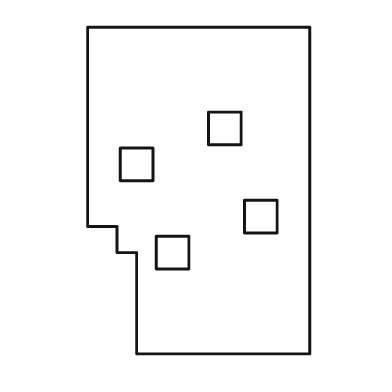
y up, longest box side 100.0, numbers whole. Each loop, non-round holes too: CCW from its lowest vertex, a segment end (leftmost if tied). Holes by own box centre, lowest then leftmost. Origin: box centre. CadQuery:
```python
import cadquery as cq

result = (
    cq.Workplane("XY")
    .moveTo(-19.0, -50.0)
    .lineTo(34.0, -50.0)
    .lineTo(34.0, 50.0)
    .lineTo(-34.0, 50.0)
    .lineTo(-34.0, -11.0)
    .lineTo(-25.0, -11.0)
    .lineTo(-25.0, -19.0)
    .lineTo(-19.0, -19.0)
    .close()
    .moveTo(-13.0, -24.0)
    .lineTo(-3.0, -24.0)
    .lineTo(-3.0, -14.0)
    .lineTo(-13.0, -14.0)
    .close()
    .moveTo(14.0, -13.0)
    .lineTo(24.0, -13.0)
    .lineTo(24.0, -3.0)
    .lineTo(14.0, -3.0)
    .close()
    .moveTo(-24.0, 3.0)
    .lineTo(-14.0, 3.0)
    .lineTo(-14.0, 13.0)
    .lineTo(-24.0, 13.0)
    .close()
    .moveTo(3.0, 14.0)
    .lineTo(13.0, 14.0)
    .lineTo(13.0, 24.0)
    .lineTo(3.0, 24.0)
    .close()
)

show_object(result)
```